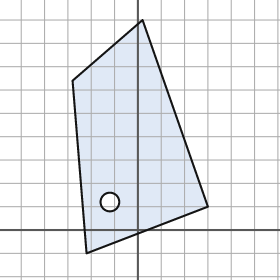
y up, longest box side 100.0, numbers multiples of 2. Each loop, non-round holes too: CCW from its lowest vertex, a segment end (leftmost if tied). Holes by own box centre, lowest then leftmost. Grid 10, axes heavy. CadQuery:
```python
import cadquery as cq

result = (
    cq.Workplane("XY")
    .moveTo(-22.0, -10.0)
    .lineTo(30.0, 10.0)
    .lineTo(2.0, 90.0)
    .lineTo(-28.0, 64.0)
    .close()
    .moveTo(-12.0, 12.0)
    .circle(4.0)
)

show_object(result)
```